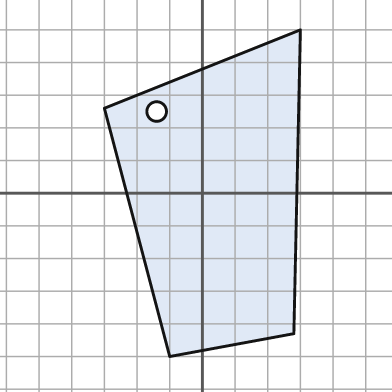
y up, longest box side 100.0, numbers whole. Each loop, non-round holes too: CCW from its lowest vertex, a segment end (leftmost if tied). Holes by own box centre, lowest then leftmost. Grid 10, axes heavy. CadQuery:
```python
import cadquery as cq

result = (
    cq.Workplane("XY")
    .moveTo(-10.0, -50.0)
    .lineTo(28.0, -43.0)
    .lineTo(30.0, 50.0)
    .lineTo(-30.0, 26.0)
    .close()
    .moveTo(-14.0, 25.0)
    .circle(3.0)
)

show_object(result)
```